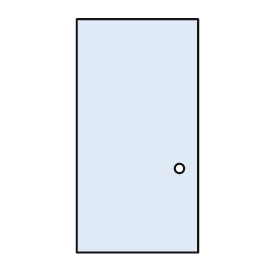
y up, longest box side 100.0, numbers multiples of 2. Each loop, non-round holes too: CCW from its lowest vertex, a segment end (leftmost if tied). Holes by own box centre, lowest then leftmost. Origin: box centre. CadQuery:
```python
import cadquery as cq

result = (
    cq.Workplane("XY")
    .moveTo(-26.0, -50.0)
    .lineTo(26.0, -50.0)
    .lineTo(26.0, 50.0)
    .lineTo(-26.0, 50.0)
    .close()
    .moveTo(18.0, -14.0)
    .circle(2.0)
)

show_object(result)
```